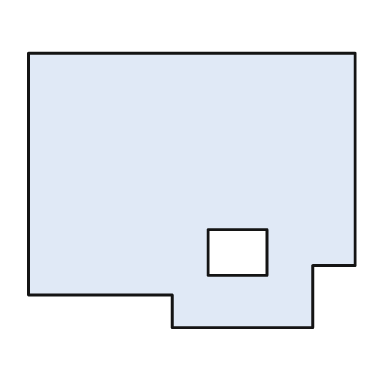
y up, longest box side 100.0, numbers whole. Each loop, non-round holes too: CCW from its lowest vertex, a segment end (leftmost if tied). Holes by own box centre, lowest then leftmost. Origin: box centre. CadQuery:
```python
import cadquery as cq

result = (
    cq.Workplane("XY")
    .moveTo(-6.0, -42.0)
    .lineTo(37.0, -42.0)
    .lineTo(37.0, -23.0)
    .lineTo(50.0, -23.0)
    .lineTo(50.0, 42.0)
    .lineTo(-50.0, 42.0)
    .lineTo(-50.0, -32.0)
    .lineTo(-6.0, -32.0)
    .close()
    .moveTo(5.0, -26.0)
    .lineTo(23.0, -26.0)
    .lineTo(23.0, -12.0)
    .lineTo(5.0, -12.0)
    .close()
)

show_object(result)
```